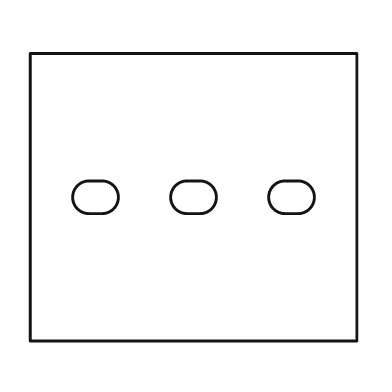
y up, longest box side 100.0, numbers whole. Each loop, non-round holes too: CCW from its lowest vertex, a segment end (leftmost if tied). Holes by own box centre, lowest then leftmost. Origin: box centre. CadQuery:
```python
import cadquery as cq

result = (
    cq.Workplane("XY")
    .moveTo(-50.0, -44.0)
    .lineTo(50.0, -44.0)
    .lineTo(50.0, 44.0)
    .lineTo(-50.0, 44.0)
    .close()
    .moveTo(-32.0, -5.0)
    .lineTo(-28.0, -5.0)
    .threePointArc((-23.0, 0.0), (-28.0, 5.0))
    .lineTo(-32.0, 5.0)
    .threePointArc((-37.0, 0.0), (-32.0, -5.0))
    .close()
    .moveTo(-2.0, -5.0)
    .lineTo(2.0, -5.0)
    .threePointArc((7.0, 0.0), (2.0, 5.0))
    .lineTo(-2.0, 5.0)
    .threePointArc((-7.0, 0.0), (-2.0, -5.0))
    .close()
    .moveTo(28.0, -5.0)
    .lineTo(32.0, -5.0)
    .threePointArc((37.0, 0.0), (32.0, 5.0))
    .lineTo(28.0, 5.0)
    .threePointArc((23.0, 0.0), (28.0, -5.0))
    .close()
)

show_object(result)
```